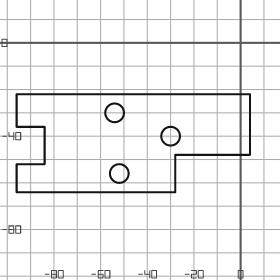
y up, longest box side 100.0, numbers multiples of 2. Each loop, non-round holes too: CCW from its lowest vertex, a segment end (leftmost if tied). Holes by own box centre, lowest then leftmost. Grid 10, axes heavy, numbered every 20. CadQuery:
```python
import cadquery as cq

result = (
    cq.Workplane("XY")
    .moveTo(-96.0, -64.0)
    .lineTo(-28.0, -64.0)
    .lineTo(-28.0, -48.0)
    .lineTo(4.0, -48.0)
    .lineTo(4.0, -22.0)
    .lineTo(-96.0, -22.0)
    .lineTo(-96.0, -36.0)
    .lineTo(-84.0, -36.0)
    .lineTo(-84.0, -52.0)
    .lineTo(-96.0, -52.0)
    .close()
    .moveTo(-52.0, -56.0)
    .circle(4.0)
    .moveTo(-30.0, -40.0)
    .circle(4.0)
    .moveTo(-54.0, -30.0)
    .circle(4.0)
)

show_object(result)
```